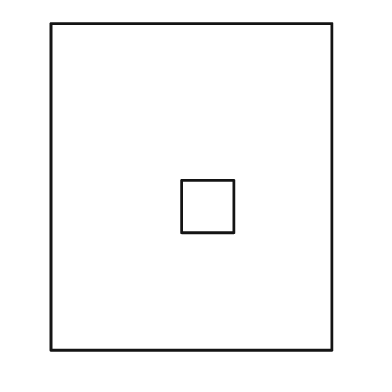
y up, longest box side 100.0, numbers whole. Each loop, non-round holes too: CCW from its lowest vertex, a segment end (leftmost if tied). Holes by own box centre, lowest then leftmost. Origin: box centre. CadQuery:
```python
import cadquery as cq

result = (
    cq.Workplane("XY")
    .moveTo(-43.0, -50.0)
    .lineTo(43.0, -50.0)
    .lineTo(43.0, 50.0)
    .lineTo(-43.0, 50.0)
    .close()
    .moveTo(-3.0, -14.0)
    .lineTo(13.0, -14.0)
    .lineTo(13.0, 2.0)
    .lineTo(-3.0, 2.0)
    .close()
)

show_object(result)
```